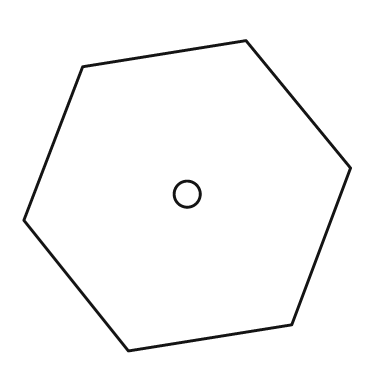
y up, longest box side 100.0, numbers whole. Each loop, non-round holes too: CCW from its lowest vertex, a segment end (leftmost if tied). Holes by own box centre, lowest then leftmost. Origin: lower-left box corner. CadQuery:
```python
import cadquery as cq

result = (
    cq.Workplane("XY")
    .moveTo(32.0, 0.0)
    .lineTo(82.0, 8.0)
    .lineTo(100.0, 56.0)
    .lineTo(68.0, 95.0)
    .lineTo(18.0, 87.0)
    .lineTo(0.0, 40.0)
    .close()
    .moveTo(50.0, 48.0)
    .circle(4.0)
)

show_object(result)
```